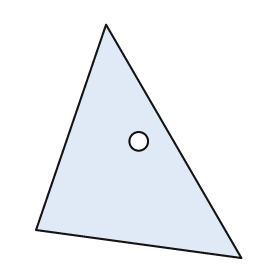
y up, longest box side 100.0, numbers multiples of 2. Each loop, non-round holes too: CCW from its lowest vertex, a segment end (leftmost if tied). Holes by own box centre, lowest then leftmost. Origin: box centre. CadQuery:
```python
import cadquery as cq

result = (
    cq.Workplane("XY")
    .moveTo(44.0, -50.0)
    .lineTo(-14.0, 50.0)
    .lineTo(-44.0, -38.0)
    .close()
    .moveTo(0.0, 0.0)
    .circle(4.0)
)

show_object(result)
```